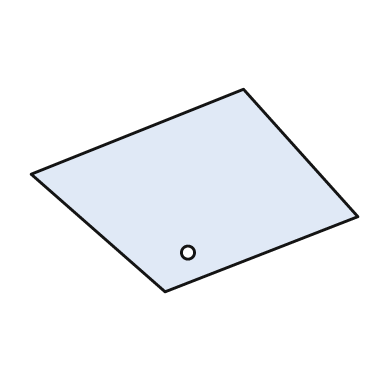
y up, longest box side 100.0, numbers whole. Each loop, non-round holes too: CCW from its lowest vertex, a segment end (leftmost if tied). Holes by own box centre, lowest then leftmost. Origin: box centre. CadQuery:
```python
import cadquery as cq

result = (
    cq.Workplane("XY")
    .moveTo(-9.0, -31.0)
    .lineTo(50.0, -8.0)
    .lineTo(15.0, 31.0)
    .lineTo(-50.0, 5.0)
    .close()
    .moveTo(-2.0, -19.0)
    .circle(2.0)
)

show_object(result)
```